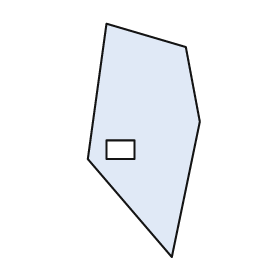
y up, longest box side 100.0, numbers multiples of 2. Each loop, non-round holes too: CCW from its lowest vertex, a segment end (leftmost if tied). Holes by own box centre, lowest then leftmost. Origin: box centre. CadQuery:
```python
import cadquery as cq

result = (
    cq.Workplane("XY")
    .moveTo(12.0, -50.0)
    .lineTo(24.0, 8.0)
    .lineTo(18.0, 40.0)
    .lineTo(-16.0, 50.0)
    .lineTo(-24.0, -8.0)
    .close()
    .moveTo(-16.0, -8.0)
    .lineTo(-4.0, -8.0)
    .lineTo(-4.0, 0.0)
    .lineTo(-16.0, 0.0)
    .close()
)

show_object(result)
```